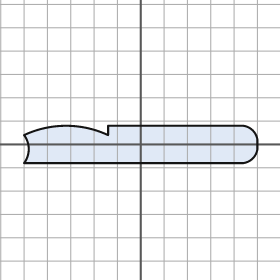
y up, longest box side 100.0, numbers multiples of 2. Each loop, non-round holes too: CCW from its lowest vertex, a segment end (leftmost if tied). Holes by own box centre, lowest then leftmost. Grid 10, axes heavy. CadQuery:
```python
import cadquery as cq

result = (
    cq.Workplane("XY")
    .moveTo(-50.0, -8.0)
    .lineTo(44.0, -8.0)
    .threePointArc((48.0, -6.0), (50.0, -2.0))
    .lineTo(50.0, 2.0)
    .threePointArc((48.0, 6.0), (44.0, 8.0))
    .lineTo(-14.0, 8.0)
    .lineTo(-14.0, 4.0)
    .threePointArc((-32.0, 8.0), (-50.0, 4.0))
    .threePointArc((-48.0, -2.0), (-50.0, -8.0))
    .close()
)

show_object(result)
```